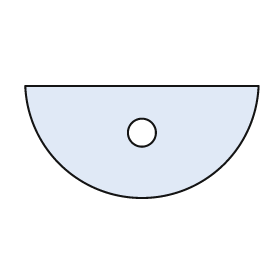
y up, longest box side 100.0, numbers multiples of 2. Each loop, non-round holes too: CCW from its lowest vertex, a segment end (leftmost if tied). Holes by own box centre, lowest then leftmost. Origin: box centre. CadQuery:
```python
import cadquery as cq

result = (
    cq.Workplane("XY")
    .moveTo(-50.0, 24.0)
    .threePointArc((0.0, -24.0), (50.0, 24.0))
    .close()
    .moveTo(0.0, 4.0)
    .circle(6.0)
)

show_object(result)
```